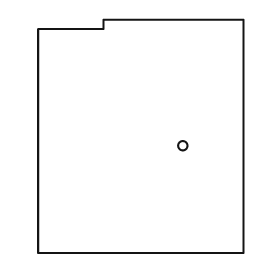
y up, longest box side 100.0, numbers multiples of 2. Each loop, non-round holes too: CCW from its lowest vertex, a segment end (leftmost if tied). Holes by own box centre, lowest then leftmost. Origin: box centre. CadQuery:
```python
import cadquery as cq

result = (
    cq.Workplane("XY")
    .moveTo(-44.0, -50.0)
    .lineTo(44.0, -50.0)
    .lineTo(44.0, 50.0)
    .lineTo(-16.0, 50.0)
    .lineTo(-16.0, 46.0)
    .lineTo(-44.0, 46.0)
    .close()
    .moveTo(18.0, -4.0)
    .circle(2.0)
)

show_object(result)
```